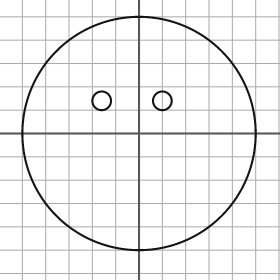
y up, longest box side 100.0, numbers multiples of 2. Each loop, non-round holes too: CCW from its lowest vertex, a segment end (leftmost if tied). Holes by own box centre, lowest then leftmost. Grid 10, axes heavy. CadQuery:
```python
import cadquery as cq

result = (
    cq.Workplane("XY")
    .moveTo(0.0, 0.0)
    .circle(50.0)
    .moveTo(-16.0, 14.0)
    .circle(4.0)
    .moveTo(10.0, 14.0)
    .circle(4.0)
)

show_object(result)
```